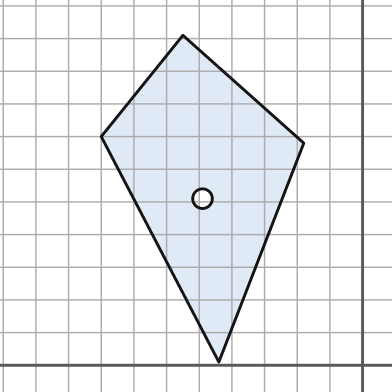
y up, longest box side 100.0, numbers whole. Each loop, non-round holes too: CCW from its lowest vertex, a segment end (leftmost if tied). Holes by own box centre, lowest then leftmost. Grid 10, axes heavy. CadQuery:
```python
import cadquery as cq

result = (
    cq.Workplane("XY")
    .moveTo(-44.0, 1.0)
    .lineTo(-18.0, 68.0)
    .lineTo(-55.0, 101.0)
    .lineTo(-80.0, 70.0)
    .close()
    .moveTo(-49.0, 51.0)
    .circle(3.0)
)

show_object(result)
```